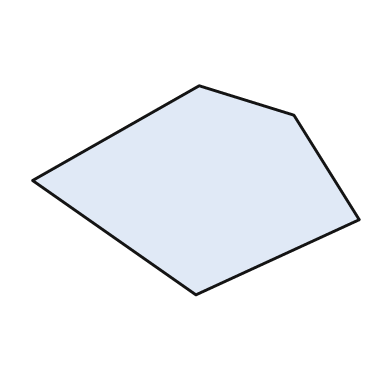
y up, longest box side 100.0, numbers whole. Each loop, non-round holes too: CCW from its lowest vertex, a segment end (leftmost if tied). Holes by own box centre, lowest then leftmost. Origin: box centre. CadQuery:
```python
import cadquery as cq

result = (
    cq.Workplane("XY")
    .moveTo(0.0, -32.0)
    .lineTo(50.0, -9.0)
    .lineTo(30.0, 23.0)
    .lineTo(1.0, 32.0)
    .lineTo(-50.0, 3.0)
    .close()
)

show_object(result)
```